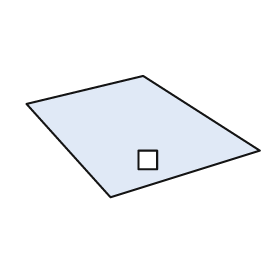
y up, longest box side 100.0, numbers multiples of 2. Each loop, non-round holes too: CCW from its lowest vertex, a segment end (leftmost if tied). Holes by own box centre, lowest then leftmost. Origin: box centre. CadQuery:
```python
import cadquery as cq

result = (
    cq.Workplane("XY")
    .moveTo(-14.0, -26.0)
    .lineTo(50.0, -6.0)
    .lineTo(0.0, 26.0)
    .lineTo(-50.0, 14.0)
    .close()
    .moveTo(-2.0, -14.0)
    .lineTo(6.0, -14.0)
    .lineTo(6.0, -6.0)
    .lineTo(-2.0, -6.0)
    .close()
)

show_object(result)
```